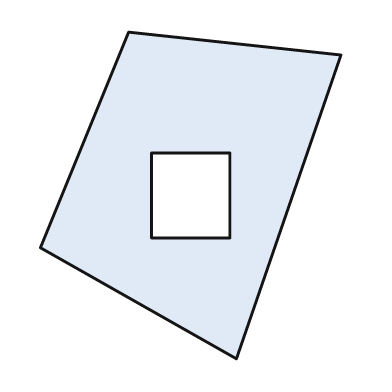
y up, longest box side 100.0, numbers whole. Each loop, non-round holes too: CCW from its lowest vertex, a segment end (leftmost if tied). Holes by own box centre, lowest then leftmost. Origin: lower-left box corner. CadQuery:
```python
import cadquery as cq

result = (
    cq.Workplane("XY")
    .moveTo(60.0, 0.0)
    .lineTo(92.0, 93.0)
    .lineTo(27.0, 100.0)
    .lineTo(0.0, 34.0)
    .close()
    .moveTo(34.0, 37.0)
    .lineTo(58.0, 37.0)
    .lineTo(58.0, 63.0)
    .lineTo(34.0, 63.0)
    .close()
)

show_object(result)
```